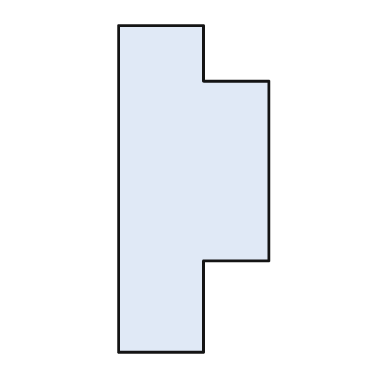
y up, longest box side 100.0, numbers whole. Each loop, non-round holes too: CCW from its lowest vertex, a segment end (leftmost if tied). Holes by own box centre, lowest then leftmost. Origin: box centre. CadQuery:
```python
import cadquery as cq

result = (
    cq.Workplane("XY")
    .moveTo(-23.0, -50.0)
    .lineTo(3.0, -50.0)
    .lineTo(3.0, -22.0)
    .lineTo(23.0, -22.0)
    .lineTo(23.0, 33.0)
    .lineTo(3.0, 33.0)
    .lineTo(3.0, 50.0)
    .lineTo(-23.0, 50.0)
    .close()
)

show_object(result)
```